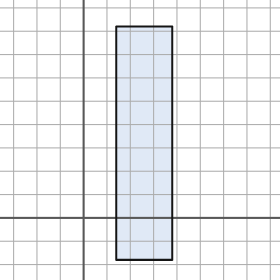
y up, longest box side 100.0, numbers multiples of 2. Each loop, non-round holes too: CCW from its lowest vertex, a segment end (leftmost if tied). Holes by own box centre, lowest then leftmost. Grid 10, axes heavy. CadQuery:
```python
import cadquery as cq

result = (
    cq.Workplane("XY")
    .moveTo(14.0, -18.0)
    .lineTo(38.0, -18.0)
    .lineTo(38.0, 82.0)
    .lineTo(14.0, 82.0)
    .close()
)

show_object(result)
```